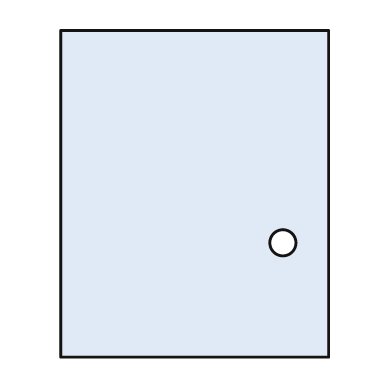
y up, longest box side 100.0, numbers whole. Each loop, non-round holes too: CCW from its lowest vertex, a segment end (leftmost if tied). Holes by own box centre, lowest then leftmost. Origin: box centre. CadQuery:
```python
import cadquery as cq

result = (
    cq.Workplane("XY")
    .moveTo(-41.0, -50.0)
    .lineTo(41.0, -50.0)
    .lineTo(41.0, 50.0)
    .lineTo(-41.0, 50.0)
    .close()
    .moveTo(27.0, -15.0)
    .circle(4.0)
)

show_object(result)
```